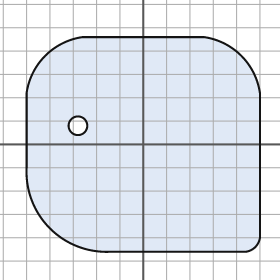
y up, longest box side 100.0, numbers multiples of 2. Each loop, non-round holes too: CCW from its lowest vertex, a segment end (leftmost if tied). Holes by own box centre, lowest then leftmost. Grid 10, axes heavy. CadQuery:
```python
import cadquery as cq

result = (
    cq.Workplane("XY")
    .moveTo(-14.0, -46.0)
    .lineTo(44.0, -46.0)
    .threePointArc((48.0, -44.0), (50.0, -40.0))
    .lineTo(50.0, 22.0)
    .threePointArc((42.0, 38.0), (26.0, 46.0))
    .lineTo(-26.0, 46.0)
    .threePointArc((-42.0, 38.0), (-50.0, 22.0))
    .lineTo(-50.0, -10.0)
    .threePointArc((-40.0, -36.0), (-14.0, -46.0))
    .close()
    .moveTo(-28.0, 8.0)
    .circle(4.0)
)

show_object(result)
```